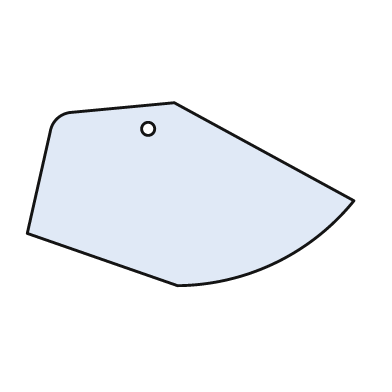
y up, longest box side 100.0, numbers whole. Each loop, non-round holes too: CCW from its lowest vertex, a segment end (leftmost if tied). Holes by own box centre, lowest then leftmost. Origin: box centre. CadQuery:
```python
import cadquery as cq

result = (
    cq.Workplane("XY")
    .moveTo(-4.0, -28.0)
    .threePointArc((26.0, -21.0), (50.0, -2.0))
    .lineTo(-5.0, 28.0)
    .lineTo(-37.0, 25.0)
    .threePointArc((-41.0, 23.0), (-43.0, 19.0))
    .lineTo(-50.0, -12.0)
    .close()
    .moveTo(-13.0, 20.0)
    .circle(2.0)
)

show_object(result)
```